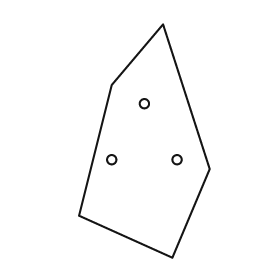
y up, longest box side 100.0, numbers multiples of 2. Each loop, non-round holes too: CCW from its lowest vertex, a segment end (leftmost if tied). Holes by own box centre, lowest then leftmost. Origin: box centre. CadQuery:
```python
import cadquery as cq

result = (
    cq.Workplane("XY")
    .moveTo(12.0, -50.0)
    .lineTo(28.0, -12.0)
    .lineTo(8.0, 50.0)
    .lineTo(-14.0, 24.0)
    .lineTo(-28.0, -32.0)
    .close()
    .moveTo(-14.0, -8.0)
    .circle(2.0)
    .moveTo(14.0, -8.0)
    .circle(2.0)
    .moveTo(0.0, 16.0)
    .circle(2.0)
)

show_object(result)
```